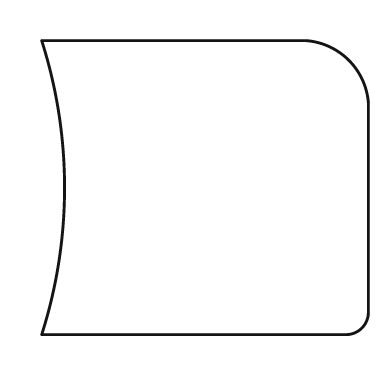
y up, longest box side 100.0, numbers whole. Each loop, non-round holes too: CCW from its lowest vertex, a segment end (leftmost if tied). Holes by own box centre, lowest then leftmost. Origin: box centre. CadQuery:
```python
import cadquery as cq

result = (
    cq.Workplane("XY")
    .moveTo(-50.0, -45.0)
    .lineTo(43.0, -45.0)
    .threePointArc((48.0, -43.0), (50.0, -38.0))
    .lineTo(50.0, 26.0)
    .threePointArc((44.0, 39.0), (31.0, 45.0))
    .lineTo(-50.0, 45.0)
    .threePointArc((-43.0, 0.0), (-50.0, -45.0))
    .close()
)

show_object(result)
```